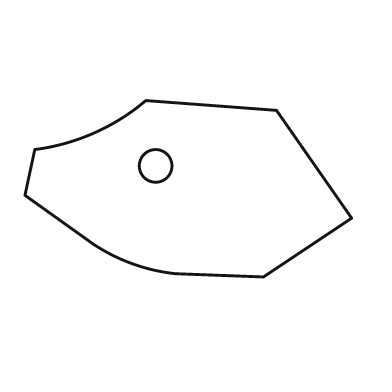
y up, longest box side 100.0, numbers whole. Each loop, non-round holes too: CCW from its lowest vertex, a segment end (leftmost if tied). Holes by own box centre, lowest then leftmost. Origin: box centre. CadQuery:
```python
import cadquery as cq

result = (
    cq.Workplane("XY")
    .moveTo(23.0, -27.0)
    .lineTo(50.0, -9.0)
    .lineTo(27.0, 24.0)
    .lineTo(-13.0, 27.0)
    .threePointArc((-29.0, 17.0), (-47.0, 12.0))
    .lineTo(-50.0, -2.0)
    .lineTo(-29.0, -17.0)
    .threePointArc((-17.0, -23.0), (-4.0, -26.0))
    .close()
    .moveTo(-10.0, 7.0)
    .circle(5.0)
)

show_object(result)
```